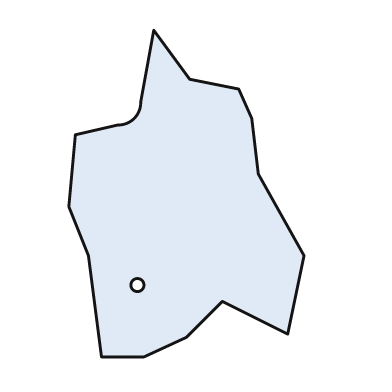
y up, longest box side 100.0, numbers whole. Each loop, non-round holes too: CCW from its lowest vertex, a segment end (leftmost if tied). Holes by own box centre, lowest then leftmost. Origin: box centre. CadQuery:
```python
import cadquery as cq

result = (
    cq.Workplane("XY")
    .moveTo(-26.0, -50.0)
    .lineTo(-13.0, -50.0)
    .lineTo(0.0, -44.0)
    .lineTo(11.0, -33.0)
    .lineTo(31.0, -43.0)
    .lineTo(36.0, -19.0)
    .lineTo(22.0, 6.0)
    .lineTo(20.0, 23.0)
    .lineTo(16.0, 32.0)
    .lineTo(1.0, 35.0)
    .lineTo(-10.0, 50.0)
    .lineTo(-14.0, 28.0)
    .threePointArc((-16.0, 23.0), (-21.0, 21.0))
    .lineTo(-34.0, 18.0)
    .lineTo(-36.0, -4.0)
    .lineTo(-30.0, -19.0)
    .close()
    .moveTo(-15.0, -28.0)
    .circle(2.0)
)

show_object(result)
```